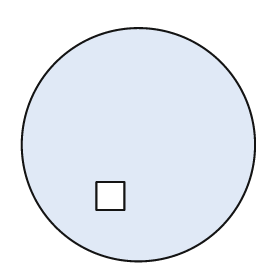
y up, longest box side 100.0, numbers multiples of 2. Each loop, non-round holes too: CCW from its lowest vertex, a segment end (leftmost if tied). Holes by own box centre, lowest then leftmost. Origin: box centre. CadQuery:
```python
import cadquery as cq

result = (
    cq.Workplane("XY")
    .moveTo(0.0, 0.0)
    .circle(50.0)
    .moveTo(-18.0, -28.0)
    .lineTo(-6.0, -28.0)
    .lineTo(-6.0, -16.0)
    .lineTo(-18.0, -16.0)
    .close()
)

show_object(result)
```